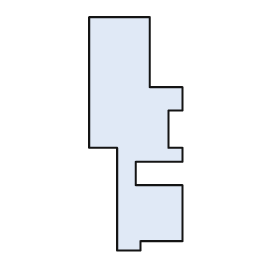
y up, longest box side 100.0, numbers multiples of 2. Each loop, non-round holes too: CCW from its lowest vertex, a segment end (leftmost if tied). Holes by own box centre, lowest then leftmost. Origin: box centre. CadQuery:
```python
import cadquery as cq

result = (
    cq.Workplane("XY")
    .moveTo(-8.0, -50.0)
    .lineTo(2.0, -50.0)
    .lineTo(2.0, -46.0)
    .lineTo(20.0, -46.0)
    .lineTo(20.0, -22.0)
    .lineTo(0.0, -22.0)
    .lineTo(0.0, -12.0)
    .lineTo(20.0, -12.0)
    .lineTo(20.0, -6.0)
    .lineTo(14.0, -6.0)
    .lineTo(14.0, 10.0)
    .lineTo(20.0, 10.0)
    .lineTo(20.0, 20.0)
    .lineTo(6.0, 20.0)
    .lineTo(6.0, 50.0)
    .lineTo(-20.0, 50.0)
    .lineTo(-20.0, -6.0)
    .lineTo(-8.0, -6.0)
    .close()
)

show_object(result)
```